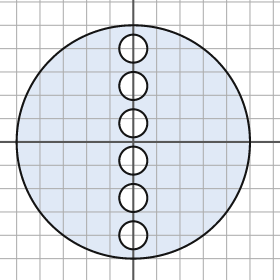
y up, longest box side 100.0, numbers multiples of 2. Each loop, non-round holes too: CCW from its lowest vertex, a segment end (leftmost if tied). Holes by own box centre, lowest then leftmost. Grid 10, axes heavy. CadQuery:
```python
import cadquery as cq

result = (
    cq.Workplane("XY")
    .moveTo(0.0, 0.0)
    .circle(50.0)
    .moveTo(0.0, -40.0)
    .circle(6.0)
    .moveTo(0.0, -24.0)
    .circle(6.0)
    .moveTo(0.0, -8.0)
    .circle(6.0)
    .moveTo(0.0, 8.0)
    .circle(6.0)
    .moveTo(0.0, 24.0)
    .circle(6.0)
    .moveTo(0.0, 40.0)
    .circle(6.0)
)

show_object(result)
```